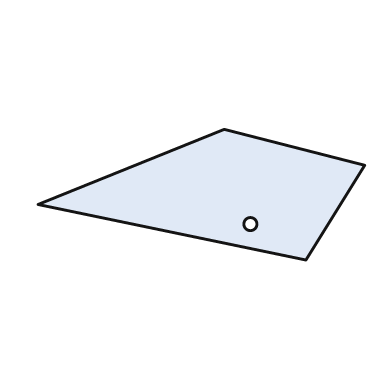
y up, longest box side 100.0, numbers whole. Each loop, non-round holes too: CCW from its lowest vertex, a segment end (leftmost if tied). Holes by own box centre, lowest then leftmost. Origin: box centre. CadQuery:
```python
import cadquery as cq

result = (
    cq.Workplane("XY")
    .moveTo(32.0, -20.0)
    .lineTo(50.0, 9.0)
    .lineTo(7.0, 20.0)
    .lineTo(-50.0, -3.0)
    .close()
    .moveTo(15.0, -9.0)
    .circle(2.0)
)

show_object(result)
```